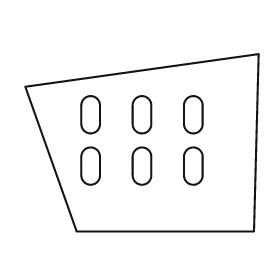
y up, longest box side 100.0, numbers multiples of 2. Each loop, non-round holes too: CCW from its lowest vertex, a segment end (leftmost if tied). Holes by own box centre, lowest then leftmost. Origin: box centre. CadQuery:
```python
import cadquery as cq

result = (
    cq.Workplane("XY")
    .moveTo(-28.0, -38.0)
    .lineTo(48.0, -38.0)
    .lineTo(50.0, 38.0)
    .lineTo(-50.0, 24.0)
    .close()
    .moveTo(-26.0, -14.0)
    .threePointArc((-22.0, -18.0), (-18.0, -14.0))
    .lineTo(-18.0, -6.0)
    .threePointArc((-22.0, -2.0), (-26.0, -6.0))
    .close()
    .moveTo(-4.0, -14.0)
    .threePointArc((0.0, -18.0), (4.0, -14.0))
    .lineTo(4.0, -6.0)
    .threePointArc((0.0, -2.0), (-4.0, -6.0))
    .close()
    .moveTo(18.0, -14.0)
    .threePointArc((22.0, -18.0), (26.0, -14.0))
    .lineTo(26.0, -6.0)
    .threePointArc((22.0, -2.0), (18.0, -6.0))
    .close()
    .moveTo(-26.0, 8.0)
    .threePointArc((-22.0, 4.0), (-18.0, 8.0))
    .lineTo(-18.0, 16.0)
    .threePointArc((-22.0, 20.0), (-26.0, 16.0))
    .close()
    .moveTo(-4.0, 8.0)
    .threePointArc((0.0, 4.0), (4.0, 8.0))
    .lineTo(4.0, 16.0)
    .threePointArc((0.0, 20.0), (-4.0, 16.0))
    .close()
    .moveTo(18.0, 8.0)
    .threePointArc((22.0, 4.0), (26.0, 8.0))
    .lineTo(26.0, 16.0)
    .threePointArc((22.0, 20.0), (18.0, 16.0))
    .close()
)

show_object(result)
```